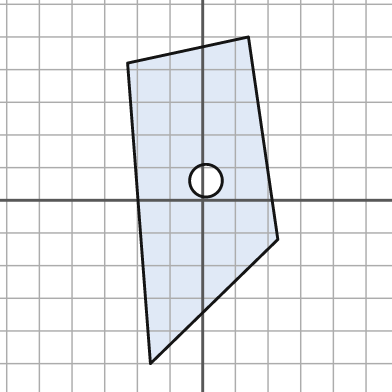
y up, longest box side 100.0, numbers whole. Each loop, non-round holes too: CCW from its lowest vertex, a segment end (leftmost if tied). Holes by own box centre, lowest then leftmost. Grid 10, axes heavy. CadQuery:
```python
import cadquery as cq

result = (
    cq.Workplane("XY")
    .moveTo(-16.0, -50.0)
    .lineTo(23.0, -12.0)
    .lineTo(14.0, 50.0)
    .lineTo(-23.0, 42.0)
    .close()
    .moveTo(1.0, 6.0)
    .circle(5.0)
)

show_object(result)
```